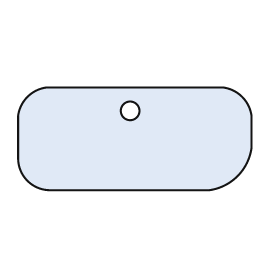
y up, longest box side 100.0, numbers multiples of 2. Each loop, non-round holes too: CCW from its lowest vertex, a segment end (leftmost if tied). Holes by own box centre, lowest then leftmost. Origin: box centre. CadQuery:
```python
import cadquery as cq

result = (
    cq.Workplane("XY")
    .moveTo(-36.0, -22.0)
    .lineTo(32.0, -22.0)
    .threePointArc((44.0, -16.0), (50.0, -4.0))
    .lineTo(50.0, 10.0)
    .threePointArc((46.0, 18.0), (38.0, 22.0))
    .lineTo(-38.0, 22.0)
    .threePointArc((-46.0, 18.0), (-50.0, 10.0))
    .lineTo(-50.0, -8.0)
    .threePointArc((-46.0, -18.0), (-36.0, -22.0))
    .close()
    .moveTo(-2.0, 12.0)
    .circle(4.0)
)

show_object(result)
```